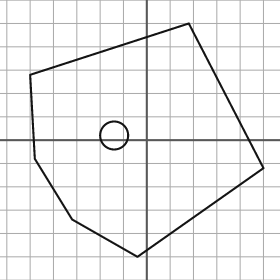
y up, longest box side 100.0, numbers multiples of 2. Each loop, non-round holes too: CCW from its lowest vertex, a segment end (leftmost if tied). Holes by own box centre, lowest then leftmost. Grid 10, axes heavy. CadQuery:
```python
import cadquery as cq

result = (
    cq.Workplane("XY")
    .moveTo(-4.0, -50.0)
    .lineTo(50.0, -12.0)
    .lineTo(18.0, 50.0)
    .lineTo(-50.0, 28.0)
    .lineTo(-48.0, -8.0)
    .lineTo(-32.0, -34.0)
    .close()
    .moveTo(-14.0, 2.0)
    .circle(6.0)
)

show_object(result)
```